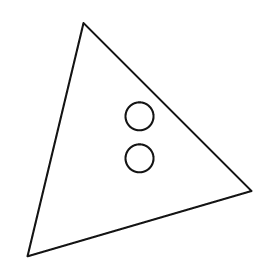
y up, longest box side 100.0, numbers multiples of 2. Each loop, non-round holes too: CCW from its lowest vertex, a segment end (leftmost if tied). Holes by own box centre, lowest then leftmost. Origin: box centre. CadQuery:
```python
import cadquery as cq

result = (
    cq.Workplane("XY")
    .moveTo(-48.0, -50.0)
    .lineTo(48.0, -22.0)
    .lineTo(-24.0, 50.0)
    .close()
    .moveTo(0.0, -8.0)
    .circle(6.0)
    .moveTo(0.0, 10.0)
    .circle(6.0)
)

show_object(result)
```